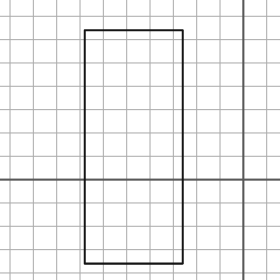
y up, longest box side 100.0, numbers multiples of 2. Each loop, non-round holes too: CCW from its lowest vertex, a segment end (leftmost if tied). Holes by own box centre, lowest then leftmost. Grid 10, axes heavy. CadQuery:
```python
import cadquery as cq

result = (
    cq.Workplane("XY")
    .moveTo(-68.0, -36.0)
    .lineTo(-26.0, -36.0)
    .lineTo(-26.0, 64.0)
    .lineTo(-68.0, 64.0)
    .close()
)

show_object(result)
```